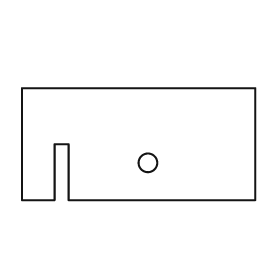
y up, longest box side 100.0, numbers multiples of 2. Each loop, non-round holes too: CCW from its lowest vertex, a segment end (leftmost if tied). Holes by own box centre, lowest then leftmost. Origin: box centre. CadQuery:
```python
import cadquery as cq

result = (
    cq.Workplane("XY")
    .moveTo(-50.0, -24.0)
    .lineTo(-36.0, -24.0)
    .lineTo(-36.0, 0.0)
    .lineTo(-30.0, 0.0)
    .lineTo(-30.0, -24.0)
    .lineTo(50.0, -24.0)
    .lineTo(50.0, 24.0)
    .lineTo(-50.0, 24.0)
    .close()
    .moveTo(4.0, -8.0)
    .circle(4.0)
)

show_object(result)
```